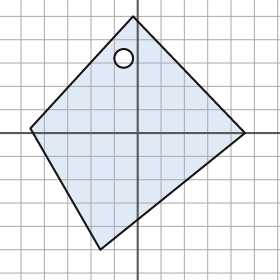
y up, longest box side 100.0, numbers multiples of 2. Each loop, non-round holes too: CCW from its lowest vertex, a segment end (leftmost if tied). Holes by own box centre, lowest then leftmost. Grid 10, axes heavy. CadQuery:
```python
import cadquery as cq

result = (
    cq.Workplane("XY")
    .moveTo(-16.0, -50.0)
    .lineTo(46.0, 0.0)
    .lineTo(-2.0, 50.0)
    .lineTo(-46.0, 2.0)
    .close()
    .moveTo(-6.0, 32.0)
    .circle(4.0)
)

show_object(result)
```